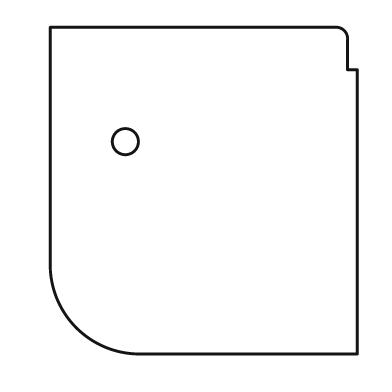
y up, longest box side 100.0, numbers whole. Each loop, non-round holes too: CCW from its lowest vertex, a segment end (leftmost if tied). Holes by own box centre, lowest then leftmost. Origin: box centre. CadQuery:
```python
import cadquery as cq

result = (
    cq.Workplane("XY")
    .moveTo(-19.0, -50.0)
    .lineTo(47.0, -50.0)
    .lineTo(47.0, 37.0)
    .lineTo(44.0, 37.0)
    .lineTo(44.0, 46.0)
    .threePointArc((43.0, 49.0), (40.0, 50.0))
    .lineTo(-47.0, 50.0)
    .lineTo(-47.0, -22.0)
    .threePointArc((-39.0, -42.0), (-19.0, -50.0))
    .close()
    .moveTo(-24.0, 15.0)
    .circle(4.0)
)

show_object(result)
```